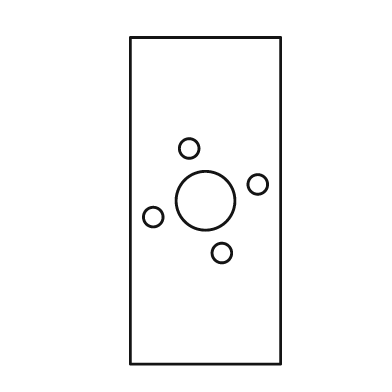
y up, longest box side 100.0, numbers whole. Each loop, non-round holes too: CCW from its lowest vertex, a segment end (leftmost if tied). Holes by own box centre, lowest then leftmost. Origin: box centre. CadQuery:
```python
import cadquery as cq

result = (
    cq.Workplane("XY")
    .moveTo(-23.0, -50.0)
    .lineTo(23.0, -50.0)
    .lineTo(23.0, 50.0)
    .lineTo(-23.0, 50.0)
    .close()
    .moveTo(5.0, -16.0)
    .circle(3.0)
    .moveTo(-16.0, -5.0)
    .circle(3.0)
    .moveTo(0.0, 0.0)
    .circle(9.0)
    .moveTo(16.0, 5.0)
    .circle(3.0)
    .moveTo(-5.0, 16.0)
    .circle(3.0)
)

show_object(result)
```